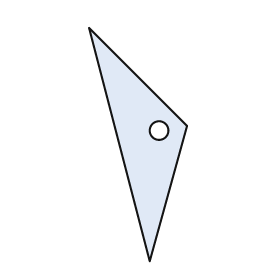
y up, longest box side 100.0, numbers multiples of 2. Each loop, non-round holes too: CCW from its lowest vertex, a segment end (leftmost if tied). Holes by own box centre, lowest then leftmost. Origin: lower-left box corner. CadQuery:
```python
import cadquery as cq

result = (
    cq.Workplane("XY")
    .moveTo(26.0, 0.0)
    .lineTo(42.0, 58.0)
    .lineTo(0.0, 100.0)
    .close()
    .moveTo(30.0, 56.0)
    .circle(4.0)
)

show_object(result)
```